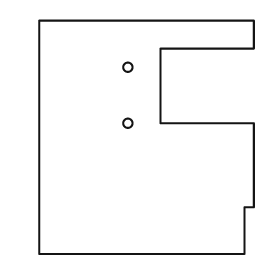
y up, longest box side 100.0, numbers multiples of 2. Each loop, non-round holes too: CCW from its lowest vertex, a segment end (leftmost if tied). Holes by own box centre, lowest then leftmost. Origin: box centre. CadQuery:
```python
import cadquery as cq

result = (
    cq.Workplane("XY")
    .moveTo(-46.0, -50.0)
    .lineTo(42.0, -50.0)
    .lineTo(42.0, -30.0)
    .lineTo(46.0, -30.0)
    .lineTo(46.0, 6.0)
    .lineTo(6.0, 6.0)
    .lineTo(6.0, 38.0)
    .lineTo(46.0, 38.0)
    .lineTo(46.0, 50.0)
    .lineTo(-46.0, 50.0)
    .close()
    .moveTo(-8.0, 6.0)
    .circle(2.0)
    .moveTo(-8.0, 30.0)
    .circle(2.0)
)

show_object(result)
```